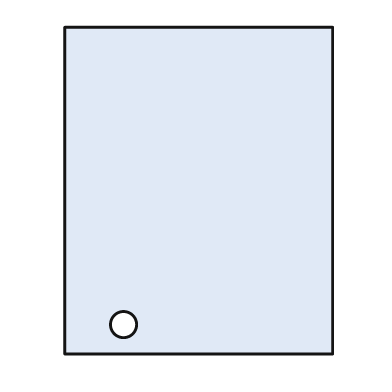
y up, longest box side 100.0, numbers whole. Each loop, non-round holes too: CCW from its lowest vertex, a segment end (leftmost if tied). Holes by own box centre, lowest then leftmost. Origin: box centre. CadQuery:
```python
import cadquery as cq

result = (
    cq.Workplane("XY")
    .moveTo(-41.0, -50.0)
    .lineTo(41.0, -50.0)
    .lineTo(41.0, 50.0)
    .lineTo(-41.0, 50.0)
    .close()
    .moveTo(-23.0, -41.0)
    .circle(4.0)
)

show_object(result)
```